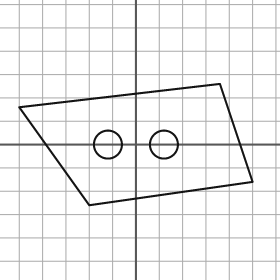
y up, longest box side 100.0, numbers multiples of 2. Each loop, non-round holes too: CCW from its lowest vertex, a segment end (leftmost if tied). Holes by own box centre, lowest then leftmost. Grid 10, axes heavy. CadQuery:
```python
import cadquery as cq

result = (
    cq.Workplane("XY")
    .moveTo(-20.0, -26.0)
    .lineTo(50.0, -16.0)
    .lineTo(36.0, 26.0)
    .lineTo(-50.0, 16.0)
    .close()
    .moveTo(-12.0, 0.0)
    .circle(6.0)
    .moveTo(12.0, 0.0)
    .circle(6.0)
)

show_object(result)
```